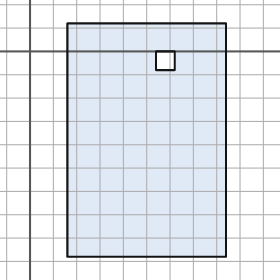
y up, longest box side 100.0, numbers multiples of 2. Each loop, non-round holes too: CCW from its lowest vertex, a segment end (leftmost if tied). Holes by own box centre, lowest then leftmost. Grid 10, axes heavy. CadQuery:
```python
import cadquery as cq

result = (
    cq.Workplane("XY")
    .moveTo(16.0, -88.0)
    .lineTo(84.0, -88.0)
    .lineTo(84.0, 12.0)
    .lineTo(16.0, 12.0)
    .close()
    .moveTo(54.0, -8.0)
    .lineTo(62.0, -8.0)
    .lineTo(62.0, 0.0)
    .lineTo(54.0, 0.0)
    .close()
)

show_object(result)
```